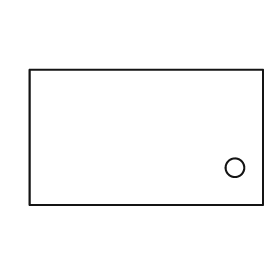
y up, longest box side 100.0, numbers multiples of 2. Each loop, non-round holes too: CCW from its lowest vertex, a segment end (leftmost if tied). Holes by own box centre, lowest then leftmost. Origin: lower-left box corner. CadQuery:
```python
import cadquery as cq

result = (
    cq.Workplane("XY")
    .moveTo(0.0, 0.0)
    .lineTo(100.0, 0.0)
    .lineTo(100.0, 58.0)
    .lineTo(0.0, 58.0)
    .close()
    .moveTo(88.0, 16.0)
    .circle(4.0)
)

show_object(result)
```